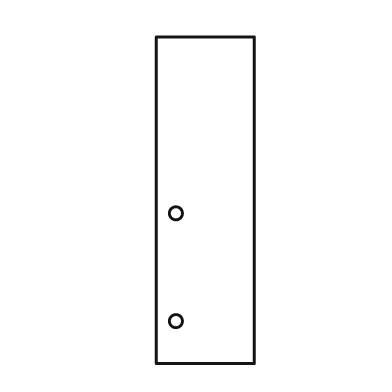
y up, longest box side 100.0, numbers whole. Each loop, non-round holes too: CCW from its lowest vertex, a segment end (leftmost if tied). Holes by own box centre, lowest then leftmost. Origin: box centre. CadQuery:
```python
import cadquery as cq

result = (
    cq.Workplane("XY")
    .moveTo(-15.0, -50.0)
    .lineTo(15.0, -50.0)
    .lineTo(15.0, 50.0)
    .lineTo(-15.0, 50.0)
    .close()
    .moveTo(-9.0, -37.0)
    .circle(2.0)
    .moveTo(-9.0, -4.0)
    .circle(2.0)
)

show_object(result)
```